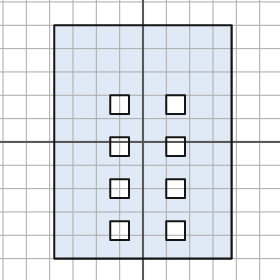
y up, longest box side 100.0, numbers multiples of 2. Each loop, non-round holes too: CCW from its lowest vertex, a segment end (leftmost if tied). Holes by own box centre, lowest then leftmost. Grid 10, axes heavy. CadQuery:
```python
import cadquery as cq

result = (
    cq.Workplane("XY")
    .moveTo(-38.0, -50.0)
    .lineTo(38.0, -50.0)
    .lineTo(38.0, 50.0)
    .lineTo(-38.0, 50.0)
    .close()
    .moveTo(-14.0, -42.0)
    .lineTo(-6.0, -42.0)
    .lineTo(-6.0, -34.0)
    .lineTo(-14.0, -34.0)
    .close()
    .moveTo(10.0, -42.0)
    .lineTo(18.0, -42.0)
    .lineTo(18.0, -34.0)
    .lineTo(10.0, -34.0)
    .close()
    .moveTo(-14.0, -24.0)
    .lineTo(-6.0, -24.0)
    .lineTo(-6.0, -16.0)
    .lineTo(-14.0, -16.0)
    .close()
    .moveTo(10.0, -24.0)
    .lineTo(18.0, -24.0)
    .lineTo(18.0, -16.0)
    .lineTo(10.0, -16.0)
    .close()
    .moveTo(-14.0, -6.0)
    .lineTo(-6.0, -6.0)
    .lineTo(-6.0, 2.0)
    .lineTo(-14.0, 2.0)
    .close()
    .moveTo(10.0, -6.0)
    .lineTo(18.0, -6.0)
    .lineTo(18.0, 2.0)
    .lineTo(10.0, 2.0)
    .close()
    .moveTo(-14.0, 12.0)
    .lineTo(-6.0, 12.0)
    .lineTo(-6.0, 20.0)
    .lineTo(-14.0, 20.0)
    .close()
    .moveTo(10.0, 12.0)
    .lineTo(18.0, 12.0)
    .lineTo(18.0, 20.0)
    .lineTo(10.0, 20.0)
    .close()
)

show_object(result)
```